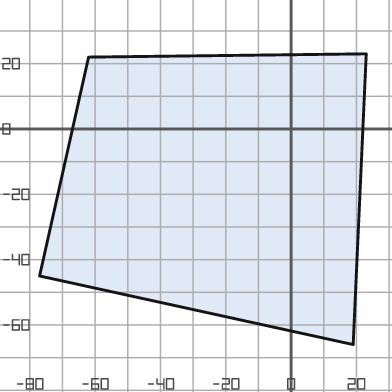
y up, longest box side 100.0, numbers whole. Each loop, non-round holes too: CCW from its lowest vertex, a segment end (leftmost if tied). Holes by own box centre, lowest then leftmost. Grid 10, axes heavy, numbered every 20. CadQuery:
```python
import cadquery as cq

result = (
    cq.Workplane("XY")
    .moveTo(19.0, -66.0)
    .lineTo(23.0, 23.0)
    .lineTo(-62.0, 22.0)
    .lineTo(-77.0, -45.0)
    .close()
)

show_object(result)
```